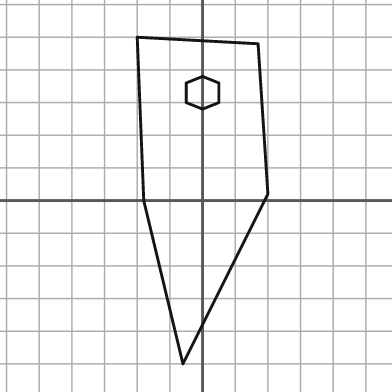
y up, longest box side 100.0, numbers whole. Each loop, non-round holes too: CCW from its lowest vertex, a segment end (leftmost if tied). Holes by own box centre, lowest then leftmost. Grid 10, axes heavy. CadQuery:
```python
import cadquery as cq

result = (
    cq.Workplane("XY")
    .moveTo(-6.0, -50.0)
    .lineTo(20.0, 2.0)
    .lineTo(17.0, 48.0)
    .lineTo(-20.0, 50.0)
    .lineTo(-18.0, 0.0)
    .close()
    .moveTo(0.0, 28.0)
    .lineTo(5.0, 30.0)
    .lineTo(5.0, 36.0)
    .lineTo(0.0, 38.0)
    .lineTo(-5.0, 36.0)
    .lineTo(-5.0, 30.0)
    .close()
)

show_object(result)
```